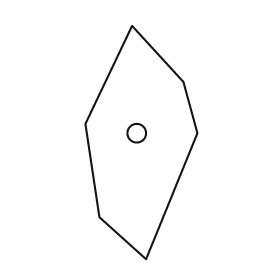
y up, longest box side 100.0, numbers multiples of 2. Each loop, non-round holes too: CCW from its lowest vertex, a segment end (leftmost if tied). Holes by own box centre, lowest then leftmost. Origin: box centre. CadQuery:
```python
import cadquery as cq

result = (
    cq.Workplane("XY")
    .moveTo(2.0, -50.0)
    .lineTo(24.0, 4.0)
    .lineTo(18.0, 26.0)
    .lineTo(-4.0, 50.0)
    .lineTo(-24.0, 8.0)
    .lineTo(-18.0, -32.0)
    .close()
    .moveTo(-2.0, 4.0)
    .circle(4.0)
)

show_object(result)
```